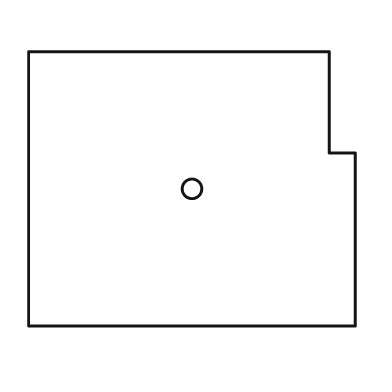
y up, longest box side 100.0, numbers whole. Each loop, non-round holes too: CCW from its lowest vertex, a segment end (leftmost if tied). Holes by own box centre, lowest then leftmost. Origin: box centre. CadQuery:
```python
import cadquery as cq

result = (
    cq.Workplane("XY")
    .moveTo(-50.0, -42.0)
    .lineTo(50.0, -42.0)
    .lineTo(50.0, 11.0)
    .lineTo(42.0, 11.0)
    .lineTo(42.0, 42.0)
    .lineTo(-50.0, 42.0)
    .close()
    .moveTo(0.0, 0.0)
    .circle(3.0)
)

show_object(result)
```